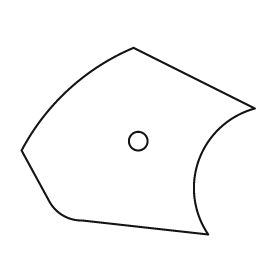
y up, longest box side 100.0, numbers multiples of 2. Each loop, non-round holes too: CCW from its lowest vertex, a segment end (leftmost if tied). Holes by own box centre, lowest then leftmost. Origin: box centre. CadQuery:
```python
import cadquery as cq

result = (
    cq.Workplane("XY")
    .moveTo(30.0, -40.0)
    .threePointArc((26.0, -8.0), (50.0, 14.0))
    .lineTo(-2.0, 40.0)
    .threePointArc((-30.0, 22.0), (-50.0, -4.0))
    .lineTo(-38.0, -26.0)
    .threePointArc((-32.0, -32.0), (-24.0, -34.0))
    .close()
    .moveTo(0.0, 0.0)
    .circle(4.0)
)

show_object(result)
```